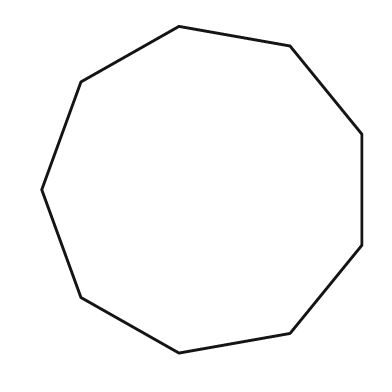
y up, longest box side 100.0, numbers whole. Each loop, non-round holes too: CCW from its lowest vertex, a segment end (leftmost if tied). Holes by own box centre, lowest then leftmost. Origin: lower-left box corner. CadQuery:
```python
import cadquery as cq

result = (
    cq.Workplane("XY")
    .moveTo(42.0, 0.0)
    .lineTo(76.0, 6.0)
    .lineTo(98.0, 33.0)
    .lineTo(98.0, 67.0)
    .lineTo(76.0, 94.0)
    .lineTo(42.0, 100.0)
    .lineTo(12.0, 83.0)
    .lineTo(0.0, 50.0)
    .lineTo(12.0, 17.0)
    .close()
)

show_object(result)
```